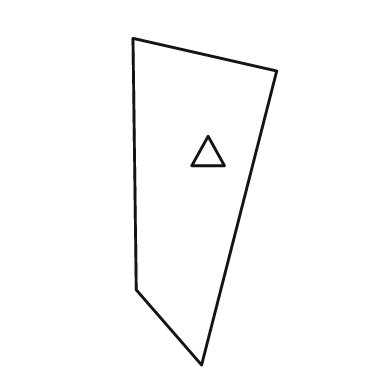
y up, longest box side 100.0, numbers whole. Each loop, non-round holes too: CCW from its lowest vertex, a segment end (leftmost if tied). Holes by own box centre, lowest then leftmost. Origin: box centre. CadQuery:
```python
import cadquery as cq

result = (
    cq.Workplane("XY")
    .moveTo(-1.0, -50.0)
    .lineTo(22.0, 40.0)
    .lineTo(-22.0, 50.0)
    .lineTo(-21.0, -27.0)
    .close()
    .moveTo(-4.0, 11.0)
    .lineTo(6.0, 11.0)
    .lineTo(1.0, 20.0)
    .close()
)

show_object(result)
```